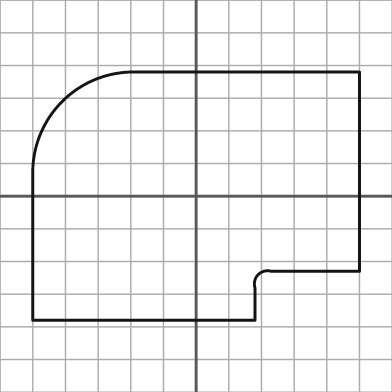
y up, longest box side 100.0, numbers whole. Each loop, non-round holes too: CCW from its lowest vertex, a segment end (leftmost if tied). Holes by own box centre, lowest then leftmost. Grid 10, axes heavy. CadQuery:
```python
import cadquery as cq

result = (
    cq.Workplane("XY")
    .moveTo(-50.0, -38.0)
    .lineTo(18.0, -38.0)
    .lineTo(18.0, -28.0)
    .threePointArc((19.0, -24.0), (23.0, -23.0))
    .lineTo(50.0, -23.0)
    .lineTo(50.0, 38.0)
    .lineTo(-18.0, 38.0)
    .threePointArc((-41.0, 29.0), (-50.0, 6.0))
    .close()
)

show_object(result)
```